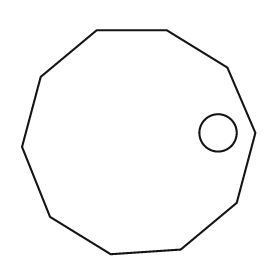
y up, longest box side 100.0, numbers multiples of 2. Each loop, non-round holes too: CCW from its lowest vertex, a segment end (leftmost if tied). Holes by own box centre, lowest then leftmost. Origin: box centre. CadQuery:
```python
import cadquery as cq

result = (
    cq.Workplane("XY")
    .moveTo(-12.0, -48.0)
    .lineTo(18.0, -46.0)
    .lineTo(42.0, -26.0)
    .lineTo(50.0, 4.0)
    .lineTo(38.0, 32.0)
    .lineTo(12.0, 48.0)
    .lineTo(-18.0, 48.0)
    .lineTo(-42.0, 28.0)
    .lineTo(-50.0, -2.0)
    .lineTo(-38.0, -32.0)
    .close()
    .moveTo(34.0, 4.0)
    .circle(8.0)
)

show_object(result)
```